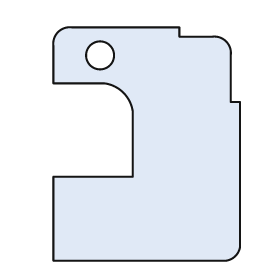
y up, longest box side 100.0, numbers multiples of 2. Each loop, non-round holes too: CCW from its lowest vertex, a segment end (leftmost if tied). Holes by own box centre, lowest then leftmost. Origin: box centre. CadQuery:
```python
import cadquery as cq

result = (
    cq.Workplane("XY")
    .moveTo(-40.0, -50.0)
    .lineTo(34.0, -50.0)
    .threePointArc((38.0, -48.0), (40.0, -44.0))
    .lineTo(40.0, 18.0)
    .lineTo(36.0, 18.0)
    .lineTo(36.0, 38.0)
    .threePointArc((34.0, 44.0), (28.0, 46.0))
    .lineTo(14.0, 46.0)
    .lineTo(14.0, 50.0)
    .lineTo(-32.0, 50.0)
    .threePointArc((-38.0, 48.0), (-40.0, 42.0))
    .lineTo(-40.0, 26.0)
    .lineTo(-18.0, 26.0)
    .threePointArc((-10.0, 22.0), (-6.0, 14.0))
    .lineTo(-6.0, -14.0)
    .lineTo(-40.0, -14.0)
    .close()
    .moveTo(-20.0, 38.0)
    .circle(6.0)
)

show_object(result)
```